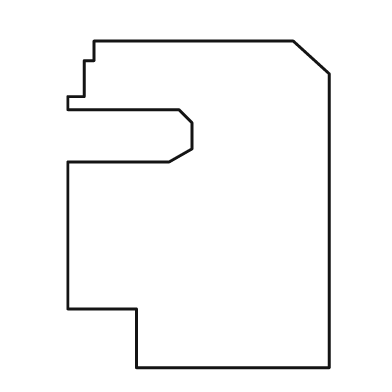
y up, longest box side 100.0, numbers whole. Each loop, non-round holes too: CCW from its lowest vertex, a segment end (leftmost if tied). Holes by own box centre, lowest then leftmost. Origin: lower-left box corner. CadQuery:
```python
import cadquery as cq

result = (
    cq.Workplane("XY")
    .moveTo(21.0, 0.0)
    .lineTo(80.0, 0.0)
    .lineTo(80.0, 90.0)
    .lineTo(69.0, 100.0)
    .lineTo(8.0, 100.0)
    .lineTo(8.0, 94.0)
    .lineTo(5.0, 94.0)
    .lineTo(5.0, 83.0)
    .lineTo(0.0, 83.0)
    .lineTo(0.0, 79.0)
    .lineTo(34.0, 79.0)
    .lineTo(38.0, 75.0)
    .lineTo(38.0, 67.0)
    .lineTo(31.0, 63.0)
    .lineTo(0.0, 63.0)
    .lineTo(0.0, 18.0)
    .lineTo(21.0, 18.0)
    .close()
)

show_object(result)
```